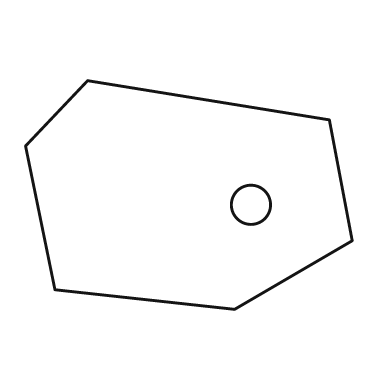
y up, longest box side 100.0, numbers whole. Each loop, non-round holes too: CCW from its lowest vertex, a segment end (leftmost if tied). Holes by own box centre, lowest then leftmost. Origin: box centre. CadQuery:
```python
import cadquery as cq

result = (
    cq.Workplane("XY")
    .moveTo(14.0, -35.0)
    .lineTo(50.0, -14.0)
    .lineTo(43.0, 23.0)
    .lineTo(-31.0, 35.0)
    .lineTo(-50.0, 15.0)
    .lineTo(-41.0, -29.0)
    .close()
    .moveTo(19.0, -3.0)
    .circle(6.0)
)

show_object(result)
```